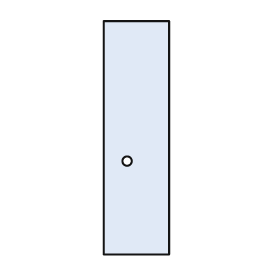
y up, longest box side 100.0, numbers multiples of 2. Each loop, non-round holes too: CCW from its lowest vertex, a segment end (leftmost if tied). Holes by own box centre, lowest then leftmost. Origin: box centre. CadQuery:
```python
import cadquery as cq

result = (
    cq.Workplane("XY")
    .moveTo(-14.0, -50.0)
    .lineTo(14.0, -50.0)
    .lineTo(14.0, 50.0)
    .lineTo(-14.0, 50.0)
    .close()
    .moveTo(-4.0, -10.0)
    .circle(2.0)
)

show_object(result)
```